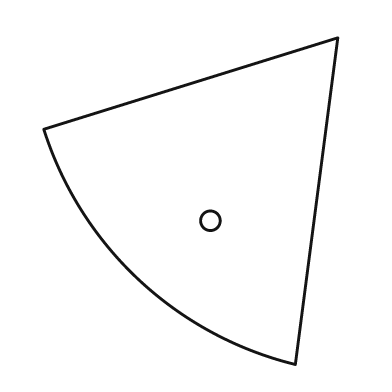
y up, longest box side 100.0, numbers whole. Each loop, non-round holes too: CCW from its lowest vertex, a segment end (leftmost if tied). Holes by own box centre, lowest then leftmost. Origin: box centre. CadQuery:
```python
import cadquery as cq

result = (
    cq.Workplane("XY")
    .moveTo(32.0, -50.0)
    .lineTo(45.0, 50.0)
    .lineTo(-45.0, 22.0)
    .threePointArc((-16.0, -24.0), (32.0, -50.0))
    .close()
    .moveTo(6.0, -6.0)
    .circle(3.0)
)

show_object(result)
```